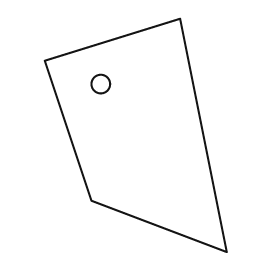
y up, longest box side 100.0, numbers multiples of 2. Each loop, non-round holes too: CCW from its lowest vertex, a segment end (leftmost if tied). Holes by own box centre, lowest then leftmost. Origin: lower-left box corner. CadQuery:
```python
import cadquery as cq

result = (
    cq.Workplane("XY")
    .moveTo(78.0, 0.0)
    .lineTo(58.0, 100.0)
    .lineTo(0.0, 82.0)
    .lineTo(20.0, 22.0)
    .close()
    .moveTo(24.0, 72.0)
    .circle(4.0)
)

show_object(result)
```